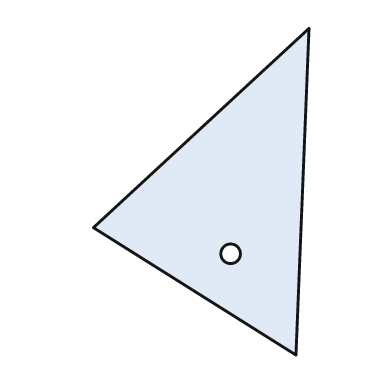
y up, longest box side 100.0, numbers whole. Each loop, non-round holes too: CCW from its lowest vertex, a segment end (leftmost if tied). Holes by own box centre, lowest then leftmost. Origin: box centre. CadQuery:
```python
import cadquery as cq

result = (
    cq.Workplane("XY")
    .moveTo(29.0, -50.0)
    .lineTo(33.0, 50.0)
    .lineTo(-33.0, -11.0)
    .close()
    .moveTo(9.0, -19.0)
    .circle(3.0)
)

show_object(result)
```